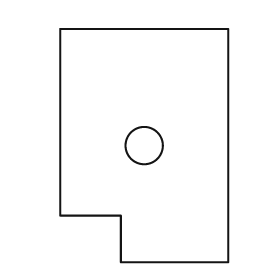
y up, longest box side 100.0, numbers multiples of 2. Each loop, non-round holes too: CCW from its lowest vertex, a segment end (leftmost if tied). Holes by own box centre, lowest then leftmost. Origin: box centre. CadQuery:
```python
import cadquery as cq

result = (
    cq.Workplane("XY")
    .moveTo(-10.0, -50.0)
    .lineTo(36.0, -50.0)
    .lineTo(36.0, 50.0)
    .lineTo(-36.0, 50.0)
    .lineTo(-36.0, -30.0)
    .lineTo(-10.0, -30.0)
    .close()
    .moveTo(0.0, 0.0)
    .circle(8.0)
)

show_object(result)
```